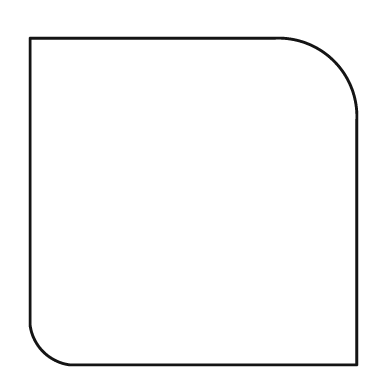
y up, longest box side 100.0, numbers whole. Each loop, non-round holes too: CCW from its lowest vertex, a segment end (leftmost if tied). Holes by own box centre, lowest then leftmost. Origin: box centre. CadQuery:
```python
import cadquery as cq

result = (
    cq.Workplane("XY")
    .moveTo(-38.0, -50.0)
    .lineTo(50.0, -50.0)
    .lineTo(50.0, 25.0)
    .threePointArc((43.0, 43.0), (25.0, 50.0))
    .lineTo(-50.0, 50.0)
    .lineTo(-50.0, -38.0)
    .threePointArc((-46.0, -46.0), (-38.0, -50.0))
    .close()
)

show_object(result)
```